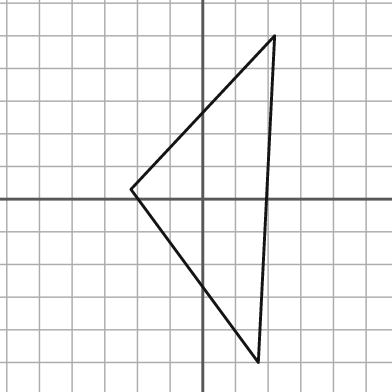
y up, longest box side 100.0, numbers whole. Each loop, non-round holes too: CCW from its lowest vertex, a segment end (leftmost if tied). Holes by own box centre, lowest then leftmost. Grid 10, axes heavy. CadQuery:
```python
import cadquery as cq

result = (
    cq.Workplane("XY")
    .moveTo(17.0, -50.0)
    .lineTo(22.0, 50.0)
    .lineTo(-22.0, 3.0)
    .close()
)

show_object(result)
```